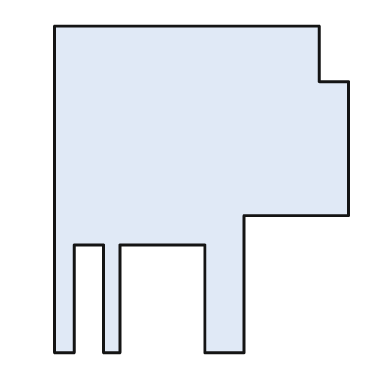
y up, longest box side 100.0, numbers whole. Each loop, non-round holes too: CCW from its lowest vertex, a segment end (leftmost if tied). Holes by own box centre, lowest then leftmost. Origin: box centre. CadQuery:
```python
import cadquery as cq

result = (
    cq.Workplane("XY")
    .moveTo(-45.0, -50.0)
    .lineTo(-39.0, -50.0)
    .lineTo(-39.0, -17.0)
    .lineTo(-30.0, -17.0)
    .lineTo(-30.0, -50.0)
    .lineTo(-25.0, -50.0)
    .lineTo(-25.0, -17.0)
    .lineTo(1.0, -17.0)
    .lineTo(1.0, -50.0)
    .lineTo(13.0, -50.0)
    .lineTo(13.0, -8.0)
    .lineTo(45.0, -8.0)
    .lineTo(45.0, 33.0)
    .lineTo(36.0, 33.0)
    .lineTo(36.0, 50.0)
    .lineTo(-45.0, 50.0)
    .close()
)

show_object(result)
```